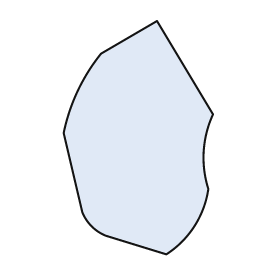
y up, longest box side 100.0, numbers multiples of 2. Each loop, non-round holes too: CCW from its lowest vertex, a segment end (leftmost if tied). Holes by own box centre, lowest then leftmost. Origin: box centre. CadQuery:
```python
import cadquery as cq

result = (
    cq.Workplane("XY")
    .moveTo(12.0, -50.0)
    .threePointArc((24.0, -38.0), (30.0, -22.0))
    .threePointArc((28.0, -6.0), (32.0, 10.0))
    .lineTo(8.0, 50.0)
    .lineTo(-16.0, 36.0)
    .threePointArc((-26.0, 20.0), (-32.0, 2.0))
    .lineTo(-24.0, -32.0)
    .threePointArc((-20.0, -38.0), (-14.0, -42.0))
    .close()
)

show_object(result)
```